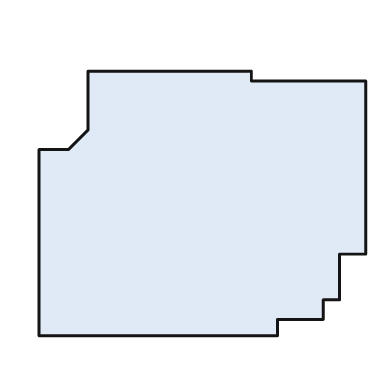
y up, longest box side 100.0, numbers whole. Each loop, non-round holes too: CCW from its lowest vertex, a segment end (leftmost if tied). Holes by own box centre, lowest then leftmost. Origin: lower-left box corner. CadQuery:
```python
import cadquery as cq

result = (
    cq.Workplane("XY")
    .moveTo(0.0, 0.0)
    .lineTo(73.0, 0.0)
    .lineTo(73.0, 5.0)
    .lineTo(87.0, 5.0)
    .lineTo(87.0, 11.0)
    .lineTo(92.0, 11.0)
    .lineTo(92.0, 25.0)
    .lineTo(100.0, 25.0)
    .lineTo(100.0, 78.0)
    .lineTo(65.0, 78.0)
    .lineTo(65.0, 81.0)
    .lineTo(15.0, 81.0)
    .lineTo(15.0, 63.0)
    .lineTo(9.0, 57.0)
    .lineTo(0.0, 57.0)
    .close()
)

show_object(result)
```